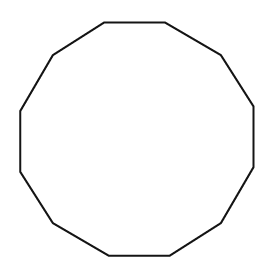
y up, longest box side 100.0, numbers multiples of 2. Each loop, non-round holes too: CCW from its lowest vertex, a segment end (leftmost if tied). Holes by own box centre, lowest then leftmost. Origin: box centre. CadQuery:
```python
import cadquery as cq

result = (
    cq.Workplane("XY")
    .moveTo(-12.0, -50.0)
    .lineTo(14.0, -50.0)
    .lineTo(36.0, -36.0)
    .lineTo(50.0, -12.0)
    .lineTo(50.0, 14.0)
    .lineTo(36.0, 36.0)
    .lineTo(12.0, 50.0)
    .lineTo(-14.0, 50.0)
    .lineTo(-36.0, 36.0)
    .lineTo(-50.0, 12.0)
    .lineTo(-50.0, -14.0)
    .lineTo(-36.0, -36.0)
    .close()
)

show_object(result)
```